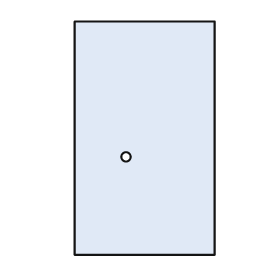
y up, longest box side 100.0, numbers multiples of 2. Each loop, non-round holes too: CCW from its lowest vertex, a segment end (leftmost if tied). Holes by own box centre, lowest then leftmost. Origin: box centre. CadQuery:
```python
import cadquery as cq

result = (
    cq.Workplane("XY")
    .moveTo(-30.0, -50.0)
    .lineTo(30.0, -50.0)
    .lineTo(30.0, 50.0)
    .lineTo(-30.0, 50.0)
    .close()
    .moveTo(-8.0, -8.0)
    .circle(2.0)
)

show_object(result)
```